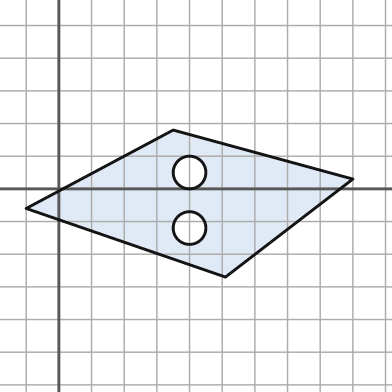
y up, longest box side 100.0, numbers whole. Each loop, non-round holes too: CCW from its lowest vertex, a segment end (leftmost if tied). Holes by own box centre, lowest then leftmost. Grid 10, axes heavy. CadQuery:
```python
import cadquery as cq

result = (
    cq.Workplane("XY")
    .moveTo(51.0, -27.0)
    .lineTo(90.0, 3.0)
    .lineTo(35.0, 18.0)
    .lineTo(-10.0, -6.0)
    .close()
    .moveTo(40.0, -12.0)
    .circle(5.0)
    .moveTo(40.0, 5.0)
    .circle(5.0)
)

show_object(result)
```